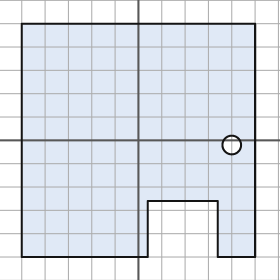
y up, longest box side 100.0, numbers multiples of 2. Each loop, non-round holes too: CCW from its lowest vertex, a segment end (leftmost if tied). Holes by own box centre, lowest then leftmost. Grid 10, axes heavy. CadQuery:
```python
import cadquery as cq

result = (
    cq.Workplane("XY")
    .moveTo(-50.0, -50.0)
    .lineTo(4.0, -50.0)
    .lineTo(4.0, -26.0)
    .lineTo(34.0, -26.0)
    .lineTo(34.0, -50.0)
    .lineTo(50.0, -50.0)
    .lineTo(50.0, 50.0)
    .lineTo(-50.0, 50.0)
    .close()
    .moveTo(40.0, -2.0)
    .circle(4.0)
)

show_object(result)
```